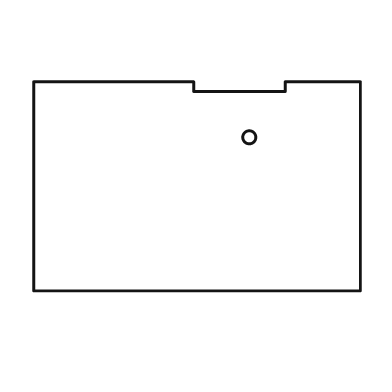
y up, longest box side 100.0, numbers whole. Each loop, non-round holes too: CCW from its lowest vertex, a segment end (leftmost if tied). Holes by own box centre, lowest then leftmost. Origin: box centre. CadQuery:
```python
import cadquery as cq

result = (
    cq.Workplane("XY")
    .moveTo(-50.0, -32.0)
    .lineTo(50.0, -32.0)
    .lineTo(50.0, 32.0)
    .lineTo(27.0, 32.0)
    .lineTo(27.0, 29.0)
    .lineTo(-1.0, 29.0)
    .lineTo(-1.0, 32.0)
    .lineTo(-50.0, 32.0)
    .close()
    .moveTo(16.0, 15.0)
    .circle(2.0)
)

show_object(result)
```